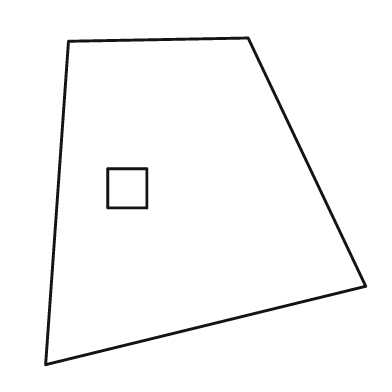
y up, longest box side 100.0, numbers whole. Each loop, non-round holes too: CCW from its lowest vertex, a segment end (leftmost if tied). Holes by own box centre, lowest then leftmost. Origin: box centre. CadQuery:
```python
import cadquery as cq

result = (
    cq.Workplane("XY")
    .moveTo(-49.0, -50.0)
    .lineTo(49.0, -26.0)
    .lineTo(13.0, 50.0)
    .lineTo(-42.0, 49.0)
    .close()
    .moveTo(-30.0, -2.0)
    .lineTo(-18.0, -2.0)
    .lineTo(-18.0, 10.0)
    .lineTo(-30.0, 10.0)
    .close()
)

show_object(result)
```